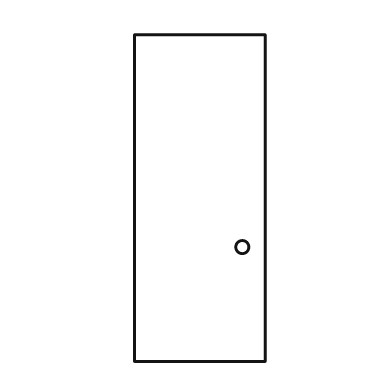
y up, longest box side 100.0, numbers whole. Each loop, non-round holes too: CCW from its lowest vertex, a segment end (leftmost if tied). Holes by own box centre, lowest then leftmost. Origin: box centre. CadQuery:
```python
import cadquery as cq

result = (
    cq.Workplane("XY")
    .moveTo(-20.0, -50.0)
    .lineTo(20.0, -50.0)
    .lineTo(20.0, 50.0)
    .lineTo(-20.0, 50.0)
    .close()
    .moveTo(13.0, -15.0)
    .circle(2.0)
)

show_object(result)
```